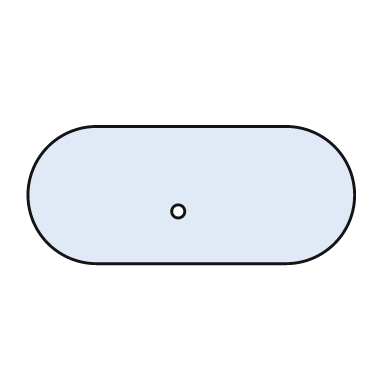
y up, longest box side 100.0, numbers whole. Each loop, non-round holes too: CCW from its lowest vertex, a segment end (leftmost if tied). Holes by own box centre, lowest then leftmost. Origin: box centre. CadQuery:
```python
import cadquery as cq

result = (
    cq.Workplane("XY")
    .moveTo(-29.0, -21.0)
    .lineTo(29.0, -21.0)
    .threePointArc((50.0, 0.0), (29.0, 21.0))
    .lineTo(-29.0, 21.0)
    .threePointArc((-50.0, 0.0), (-29.0, -21.0))
    .close()
    .moveTo(-4.0, -5.0)
    .circle(2.0)
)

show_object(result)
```